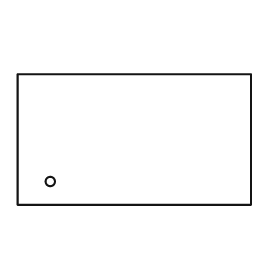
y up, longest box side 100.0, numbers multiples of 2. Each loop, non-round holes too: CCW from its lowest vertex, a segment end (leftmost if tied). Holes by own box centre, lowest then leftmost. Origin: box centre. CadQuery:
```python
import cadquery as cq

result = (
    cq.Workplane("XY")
    .moveTo(-50.0, -28.0)
    .lineTo(50.0, -28.0)
    .lineTo(50.0, 28.0)
    .lineTo(-50.0, 28.0)
    .close()
    .moveTo(-36.0, -18.0)
    .circle(2.0)
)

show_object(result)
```